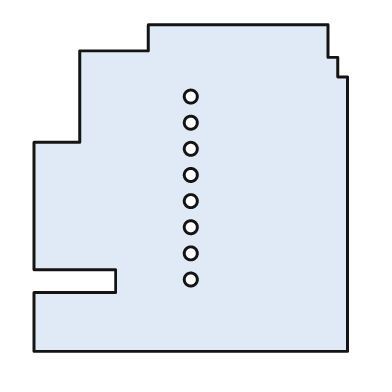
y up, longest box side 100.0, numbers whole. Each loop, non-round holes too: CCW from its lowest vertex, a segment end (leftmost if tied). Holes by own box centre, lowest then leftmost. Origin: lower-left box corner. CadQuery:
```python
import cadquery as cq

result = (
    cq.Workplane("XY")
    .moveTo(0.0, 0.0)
    .lineTo(96.0, 0.0)
    .lineTo(96.0, 84.0)
    .lineTo(93.0, 84.0)
    .lineTo(93.0, 90.0)
    .lineTo(90.0, 90.0)
    .lineTo(90.0, 100.0)
    .lineTo(35.0, 100.0)
    .lineTo(35.0, 92.0)
    .lineTo(14.0, 92.0)
    .lineTo(14.0, 64.0)
    .lineTo(0.0, 64.0)
    .lineTo(0.0, 25.0)
    .lineTo(25.0, 25.0)
    .lineTo(25.0, 18.0)
    .lineTo(0.0, 18.0)
    .close()
    .moveTo(48.0, 22.0)
    .circle(2.0)
    .moveTo(48.0, 30.0)
    .circle(2.0)
    .moveTo(48.0, 38.0)
    .circle(2.0)
    .moveTo(48.0, 46.0)
    .circle(2.0)
    .moveTo(48.0, 54.0)
    .circle(2.0)
    .moveTo(48.0, 62.0)
    .circle(2.0)
    .moveTo(48.0, 70.0)
    .circle(2.0)
    .moveTo(48.0, 78.0)
    .circle(2.0)
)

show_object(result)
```